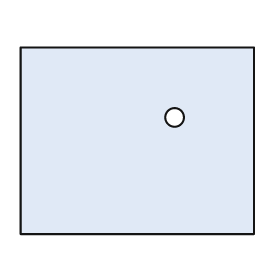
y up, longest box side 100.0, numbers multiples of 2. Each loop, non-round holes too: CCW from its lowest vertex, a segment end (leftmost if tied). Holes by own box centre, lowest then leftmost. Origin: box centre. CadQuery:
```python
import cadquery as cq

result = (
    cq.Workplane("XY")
    .moveTo(-50.0, -40.0)
    .lineTo(50.0, -40.0)
    .lineTo(50.0, 40.0)
    .lineTo(-50.0, 40.0)
    .close()
    .moveTo(16.0, 10.0)
    .circle(4.0)
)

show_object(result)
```